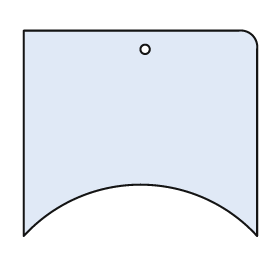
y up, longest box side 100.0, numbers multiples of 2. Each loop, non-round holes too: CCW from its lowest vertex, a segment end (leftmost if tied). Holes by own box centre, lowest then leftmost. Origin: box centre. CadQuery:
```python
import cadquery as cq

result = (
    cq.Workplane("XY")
    .moveTo(-50.0, -44.0)
    .threePointArc((0.0, -22.0), (50.0, -44.0))
    .lineTo(50.0, 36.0)
    .threePointArc((48.0, 42.0), (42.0, 44.0))
    .lineTo(-50.0, 44.0)
    .close()
    .moveTo(2.0, 36.0)
    .circle(2.0)
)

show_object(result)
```